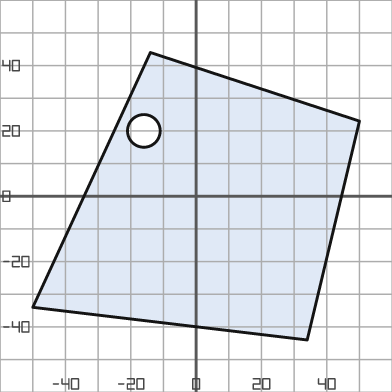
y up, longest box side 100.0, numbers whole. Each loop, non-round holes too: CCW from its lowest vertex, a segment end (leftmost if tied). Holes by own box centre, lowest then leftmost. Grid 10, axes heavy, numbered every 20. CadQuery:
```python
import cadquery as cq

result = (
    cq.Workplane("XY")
    .moveTo(34.0, -44.0)
    .lineTo(50.0, 23.0)
    .lineTo(-14.0, 44.0)
    .lineTo(-50.0, -34.0)
    .close()
    .moveTo(-16.0, 20.0)
    .circle(5.0)
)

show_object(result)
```